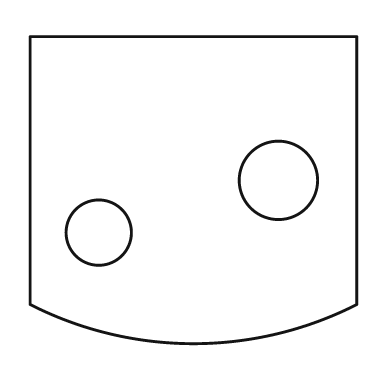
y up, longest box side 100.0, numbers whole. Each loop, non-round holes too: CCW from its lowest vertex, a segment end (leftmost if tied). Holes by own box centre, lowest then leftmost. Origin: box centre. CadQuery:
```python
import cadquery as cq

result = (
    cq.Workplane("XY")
    .moveTo(-50.0, -35.0)
    .threePointArc((0.0, -47.0), (50.0, -35.0))
    .lineTo(50.0, 47.0)
    .lineTo(-50.0, 47.0)
    .close()
    .moveTo(-29.0, -13.0)
    .circle(10.0)
    .moveTo(26.0, 3.0)
    .circle(12.0)
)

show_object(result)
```